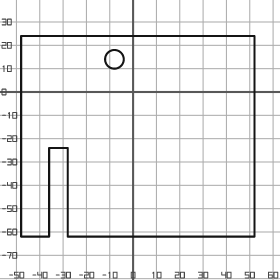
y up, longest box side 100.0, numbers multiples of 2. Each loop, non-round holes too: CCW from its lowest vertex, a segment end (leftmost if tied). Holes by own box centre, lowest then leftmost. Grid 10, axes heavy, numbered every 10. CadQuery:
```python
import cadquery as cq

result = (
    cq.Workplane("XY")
    .moveTo(-48.0, -62.0)
    .lineTo(-36.0, -62.0)
    .lineTo(-36.0, -24.0)
    .lineTo(-28.0, -24.0)
    .lineTo(-28.0, -62.0)
    .lineTo(52.0, -62.0)
    .lineTo(52.0, 24.0)
    .lineTo(-48.0, 24.0)
    .close()
    .moveTo(-8.0, 14.0)
    .circle(4.0)
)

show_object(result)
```